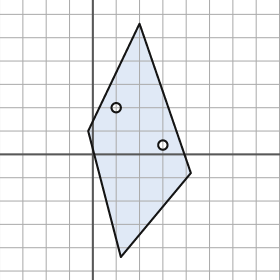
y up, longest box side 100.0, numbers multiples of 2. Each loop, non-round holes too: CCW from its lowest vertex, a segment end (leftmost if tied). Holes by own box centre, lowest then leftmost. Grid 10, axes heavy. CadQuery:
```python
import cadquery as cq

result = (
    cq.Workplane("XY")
    .moveTo(12.0, -44.0)
    .lineTo(42.0, -8.0)
    .lineTo(20.0, 56.0)
    .lineTo(-2.0, 10.0)
    .close()
    .moveTo(30.0, 4.0)
    .circle(2.0)
    .moveTo(10.0, 20.0)
    .circle(2.0)
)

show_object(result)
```